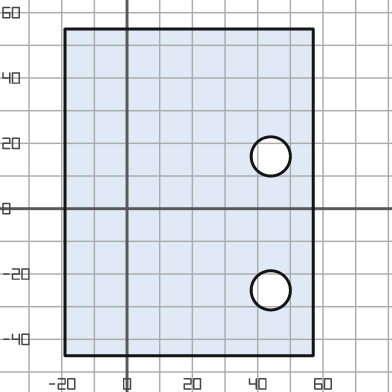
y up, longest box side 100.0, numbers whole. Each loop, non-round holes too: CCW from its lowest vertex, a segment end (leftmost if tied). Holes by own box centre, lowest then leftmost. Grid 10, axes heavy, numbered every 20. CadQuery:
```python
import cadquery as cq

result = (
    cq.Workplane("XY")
    .moveTo(-19.0, -45.0)
    .lineTo(57.0, -45.0)
    .lineTo(57.0, 55.0)
    .lineTo(-19.0, 55.0)
    .close()
    .moveTo(44.0, -25.0)
    .circle(6.0)
    .moveTo(44.0, 16.0)
    .circle(6.0)
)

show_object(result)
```